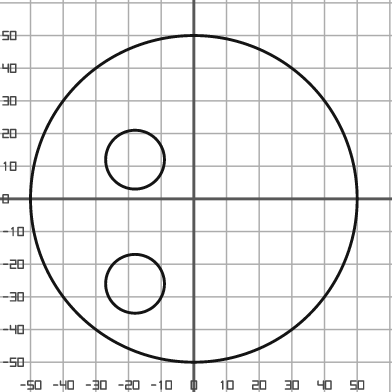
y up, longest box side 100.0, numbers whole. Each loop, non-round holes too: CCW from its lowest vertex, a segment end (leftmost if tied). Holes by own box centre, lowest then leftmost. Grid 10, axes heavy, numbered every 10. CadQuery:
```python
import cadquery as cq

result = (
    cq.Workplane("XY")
    .moveTo(0.0, 0.0)
    .circle(50.0)
    .moveTo(-18.0, -26.0)
    .circle(9.0)
    .moveTo(-18.0, 12.0)
    .circle(9.0)
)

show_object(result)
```